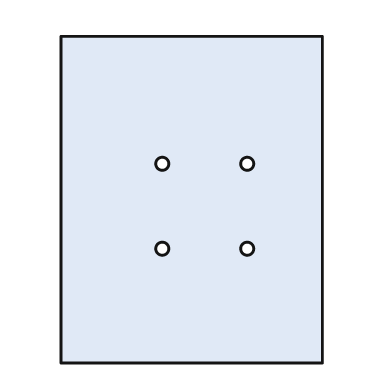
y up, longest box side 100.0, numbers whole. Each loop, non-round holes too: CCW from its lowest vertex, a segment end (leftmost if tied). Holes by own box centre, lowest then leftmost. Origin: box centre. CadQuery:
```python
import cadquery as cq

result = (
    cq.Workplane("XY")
    .moveTo(-40.0, -50.0)
    .lineTo(40.0, -50.0)
    .lineTo(40.0, 50.0)
    .lineTo(-40.0, 50.0)
    .close()
    .moveTo(-9.0, -15.0)
    .circle(2.0)
    .moveTo(17.0, -15.0)
    .circle(2.0)
    .moveTo(-9.0, 11.0)
    .circle(2.0)
    .moveTo(17.0, 11.0)
    .circle(2.0)
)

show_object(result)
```